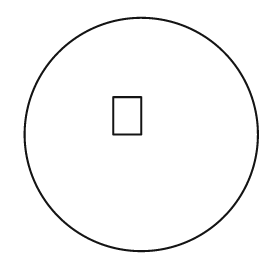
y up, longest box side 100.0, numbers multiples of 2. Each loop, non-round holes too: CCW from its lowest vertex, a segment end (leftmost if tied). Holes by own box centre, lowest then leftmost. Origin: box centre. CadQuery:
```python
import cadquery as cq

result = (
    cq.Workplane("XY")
    .moveTo(0.0, 0.0)
    .circle(50.0)
    .moveTo(-12.0, 0.0)
    .lineTo(0.0, 0.0)
    .lineTo(0.0, 16.0)
    .lineTo(-12.0, 16.0)
    .close()
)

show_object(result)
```